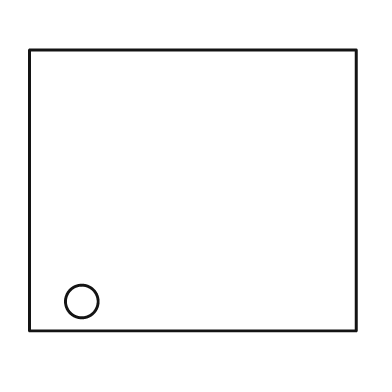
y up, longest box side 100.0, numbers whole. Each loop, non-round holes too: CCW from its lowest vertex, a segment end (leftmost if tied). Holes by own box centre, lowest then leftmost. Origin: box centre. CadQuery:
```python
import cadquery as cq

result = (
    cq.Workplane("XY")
    .moveTo(-50.0, -43.0)
    .lineTo(50.0, -43.0)
    .lineTo(50.0, 43.0)
    .lineTo(-50.0, 43.0)
    .close()
    .moveTo(-34.0, -34.0)
    .circle(5.0)
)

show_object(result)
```